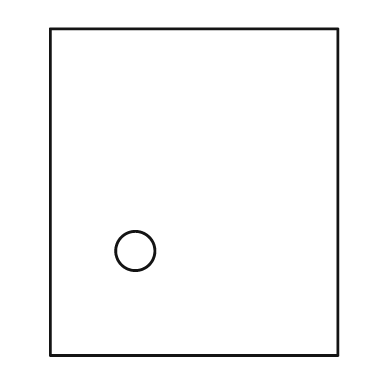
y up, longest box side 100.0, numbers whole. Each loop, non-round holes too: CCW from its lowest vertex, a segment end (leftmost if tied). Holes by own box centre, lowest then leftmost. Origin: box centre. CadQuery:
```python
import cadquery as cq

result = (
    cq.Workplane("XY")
    .moveTo(-44.0, -50.0)
    .lineTo(44.0, -50.0)
    .lineTo(44.0, 50.0)
    .lineTo(-44.0, 50.0)
    .close()
    .moveTo(-18.0, -18.0)
    .circle(6.0)
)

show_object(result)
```